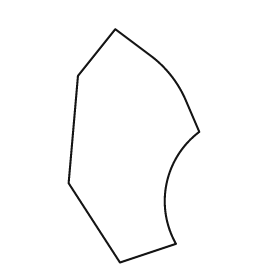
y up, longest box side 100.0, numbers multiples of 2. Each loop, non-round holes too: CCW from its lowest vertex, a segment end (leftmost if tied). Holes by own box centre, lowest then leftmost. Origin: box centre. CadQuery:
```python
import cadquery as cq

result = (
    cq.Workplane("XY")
    .moveTo(-6.0, -50.0)
    .lineTo(18.0, -42.0)
    .threePointArc((14.0, -16.0), (28.0, 6.0))
    .lineTo(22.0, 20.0)
    .threePointArc((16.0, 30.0), (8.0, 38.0))
    .lineTo(-8.0, 50.0)
    .lineTo(-24.0, 30.0)
    .lineTo(-28.0, -16.0)
    .close()
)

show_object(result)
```